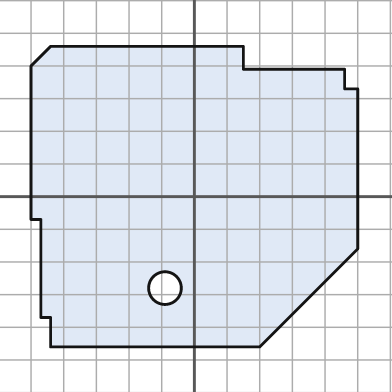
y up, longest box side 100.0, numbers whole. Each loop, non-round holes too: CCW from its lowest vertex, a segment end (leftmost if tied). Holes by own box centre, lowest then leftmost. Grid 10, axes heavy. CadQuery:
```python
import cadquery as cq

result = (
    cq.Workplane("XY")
    .moveTo(-44.0, -46.0)
    .lineTo(20.0, -46.0)
    .lineTo(50.0, -16.0)
    .lineTo(50.0, 33.0)
    .lineTo(46.0, 33.0)
    .lineTo(46.0, 39.0)
    .lineTo(15.0, 39.0)
    .lineTo(15.0, 46.0)
    .lineTo(-44.0, 46.0)
    .lineTo(-50.0, 40.0)
    .lineTo(-50.0, -7.0)
    .lineTo(-47.0, -7.0)
    .lineTo(-47.0, -37.0)
    .lineTo(-44.0, -37.0)
    .close()
    .moveTo(-9.0, -28.0)
    .circle(5.0)
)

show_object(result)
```